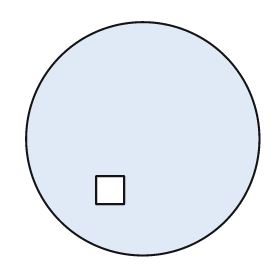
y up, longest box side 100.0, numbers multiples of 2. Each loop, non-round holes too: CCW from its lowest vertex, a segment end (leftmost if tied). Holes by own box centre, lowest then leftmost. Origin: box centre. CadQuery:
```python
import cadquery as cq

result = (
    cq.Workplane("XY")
    .moveTo(0.0, 0.0)
    .circle(50.0)
    .moveTo(-20.0, -28.0)
    .lineTo(-8.0, -28.0)
    .lineTo(-8.0, -16.0)
    .lineTo(-20.0, -16.0)
    .close()
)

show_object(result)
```